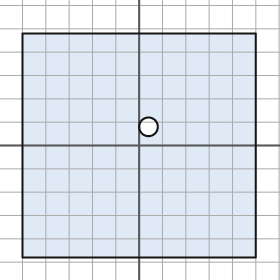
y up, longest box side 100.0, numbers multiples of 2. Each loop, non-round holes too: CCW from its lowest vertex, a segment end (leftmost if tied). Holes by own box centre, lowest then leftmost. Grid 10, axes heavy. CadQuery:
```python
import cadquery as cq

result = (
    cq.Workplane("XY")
    .moveTo(-50.0, -48.0)
    .lineTo(50.0, -48.0)
    .lineTo(50.0, 48.0)
    .lineTo(-50.0, 48.0)
    .close()
    .moveTo(4.0, 8.0)
    .circle(4.0)
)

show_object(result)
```